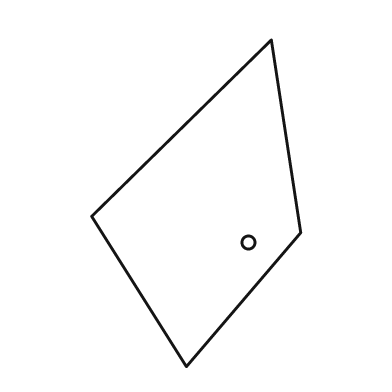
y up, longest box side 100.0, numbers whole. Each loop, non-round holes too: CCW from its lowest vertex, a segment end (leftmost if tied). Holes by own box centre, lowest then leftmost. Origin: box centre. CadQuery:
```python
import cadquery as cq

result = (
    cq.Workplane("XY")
    .moveTo(-3.0, -50.0)
    .lineTo(32.0, -9.0)
    .lineTo(23.0, 50.0)
    .lineTo(-32.0, -4.0)
    .close()
    .moveTo(16.0, -12.0)
    .circle(2.0)
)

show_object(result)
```